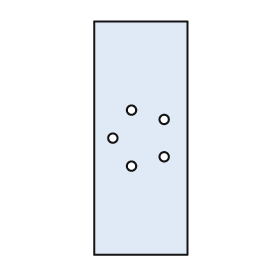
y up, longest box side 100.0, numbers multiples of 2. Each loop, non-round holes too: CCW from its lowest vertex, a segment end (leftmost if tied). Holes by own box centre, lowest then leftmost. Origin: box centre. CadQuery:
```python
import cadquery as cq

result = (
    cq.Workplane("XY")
    .moveTo(-20.0, -50.0)
    .lineTo(20.0, -50.0)
    .lineTo(20.0, 50.0)
    .lineTo(-20.0, 50.0)
    .close()
    .moveTo(-4.0, -12.0)
    .circle(2.0)
    .moveTo(10.0, -8.0)
    .circle(2.0)
    .moveTo(-12.0, 0.0)
    .circle(2.0)
    .moveTo(10.0, 8.0)
    .circle(2.0)
    .moveTo(-4.0, 12.0)
    .circle(2.0)
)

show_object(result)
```